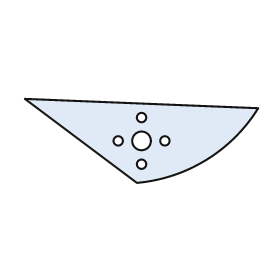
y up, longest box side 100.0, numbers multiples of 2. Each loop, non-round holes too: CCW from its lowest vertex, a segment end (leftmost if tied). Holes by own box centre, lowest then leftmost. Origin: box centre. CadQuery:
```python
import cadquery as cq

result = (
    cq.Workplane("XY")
    .moveTo(-2.0, -18.0)
    .threePointArc((28.0, -8.0), (50.0, 14.0))
    .lineTo(-50.0, 18.0)
    .close()
    .moveTo(0.0, -10.0)
    .circle(2.0)
    .moveTo(-10.0, 0.0)
    .circle(2.0)
    .moveTo(0.0, 0.0)
    .circle(4.0)
    .moveTo(10.0, 0.0)
    .circle(2.0)
    .moveTo(0.0, 10.0)
    .circle(2.0)
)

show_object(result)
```